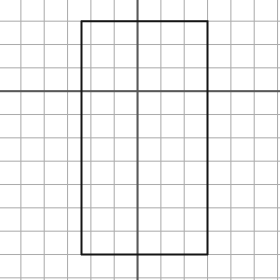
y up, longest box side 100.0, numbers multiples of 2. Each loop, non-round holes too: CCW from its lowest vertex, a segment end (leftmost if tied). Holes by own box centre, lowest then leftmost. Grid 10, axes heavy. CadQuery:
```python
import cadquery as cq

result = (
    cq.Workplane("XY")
    .moveTo(-24.0, -70.0)
    .lineTo(30.0, -70.0)
    .lineTo(30.0, 30.0)
    .lineTo(-24.0, 30.0)
    .close()
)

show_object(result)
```